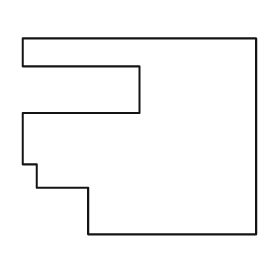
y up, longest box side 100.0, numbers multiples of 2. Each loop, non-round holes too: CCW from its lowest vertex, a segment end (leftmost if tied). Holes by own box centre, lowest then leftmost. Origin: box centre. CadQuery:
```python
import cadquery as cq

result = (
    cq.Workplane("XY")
    .moveTo(-22.0, -42.0)
    .lineTo(50.0, -42.0)
    .lineTo(50.0, 42.0)
    .lineTo(-50.0, 42.0)
    .lineTo(-50.0, 30.0)
    .lineTo(0.0, 30.0)
    .lineTo(0.0, 10.0)
    .lineTo(-50.0, 10.0)
    .lineTo(-50.0, -12.0)
    .lineTo(-44.0, -12.0)
    .lineTo(-44.0, -22.0)
    .lineTo(-22.0, -22.0)
    .close()
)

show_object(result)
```